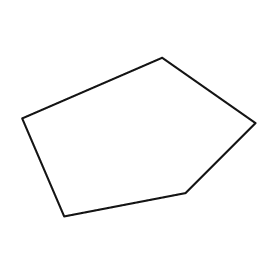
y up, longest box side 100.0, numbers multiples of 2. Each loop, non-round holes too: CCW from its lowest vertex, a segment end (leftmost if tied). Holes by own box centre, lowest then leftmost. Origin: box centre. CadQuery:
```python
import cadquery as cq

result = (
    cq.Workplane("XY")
    .moveTo(-32.0, -34.0)
    .lineTo(20.0, -24.0)
    .lineTo(50.0, 6.0)
    .lineTo(10.0, 34.0)
    .lineTo(-50.0, 8.0)
    .close()
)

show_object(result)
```